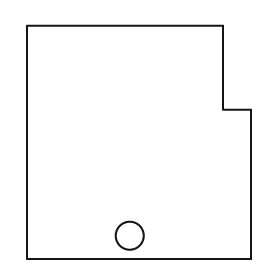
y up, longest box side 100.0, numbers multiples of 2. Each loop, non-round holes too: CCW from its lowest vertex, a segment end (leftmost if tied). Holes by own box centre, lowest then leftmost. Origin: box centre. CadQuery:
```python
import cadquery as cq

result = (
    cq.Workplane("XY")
    .moveTo(-48.0, -50.0)
    .lineTo(48.0, -50.0)
    .lineTo(48.0, 14.0)
    .lineTo(36.0, 14.0)
    .lineTo(36.0, 50.0)
    .lineTo(-48.0, 50.0)
    .close()
    .moveTo(-4.0, -40.0)
    .circle(6.0)
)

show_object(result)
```